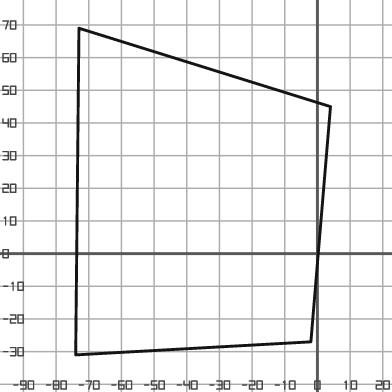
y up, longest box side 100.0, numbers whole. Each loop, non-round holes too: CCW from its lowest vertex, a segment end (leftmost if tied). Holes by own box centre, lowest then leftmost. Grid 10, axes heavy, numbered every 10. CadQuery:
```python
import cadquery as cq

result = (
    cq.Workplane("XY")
    .moveTo(-74.0, -31.0)
    .lineTo(-2.0, -27.0)
    .lineTo(4.0, 45.0)
    .lineTo(-73.0, 69.0)
    .close()
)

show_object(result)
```